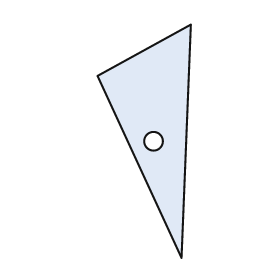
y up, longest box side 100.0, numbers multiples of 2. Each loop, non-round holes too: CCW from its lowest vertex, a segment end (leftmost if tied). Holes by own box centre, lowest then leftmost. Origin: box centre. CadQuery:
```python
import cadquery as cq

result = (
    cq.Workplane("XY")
    .moveTo(16.0, -50.0)
    .lineTo(20.0, 50.0)
    .lineTo(-20.0, 28.0)
    .close()
    .moveTo(4.0, 0.0)
    .circle(4.0)
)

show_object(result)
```